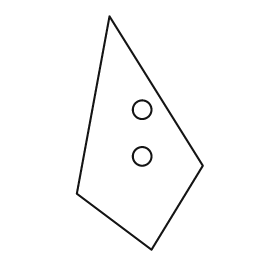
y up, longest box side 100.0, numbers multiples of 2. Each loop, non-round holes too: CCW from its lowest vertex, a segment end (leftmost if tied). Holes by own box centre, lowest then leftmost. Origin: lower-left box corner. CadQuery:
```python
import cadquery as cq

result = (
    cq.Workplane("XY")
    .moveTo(32.0, 0.0)
    .lineTo(54.0, 36.0)
    .lineTo(14.0, 100.0)
    .lineTo(0.0, 24.0)
    .close()
    .moveTo(28.0, 40.0)
    .circle(4.0)
    .moveTo(28.0, 60.0)
    .circle(4.0)
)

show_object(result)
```